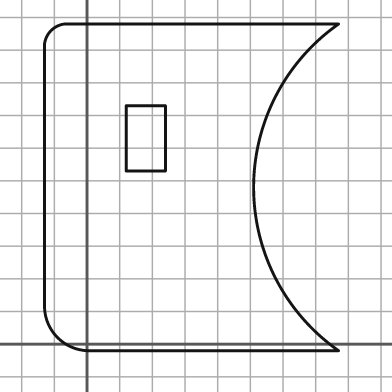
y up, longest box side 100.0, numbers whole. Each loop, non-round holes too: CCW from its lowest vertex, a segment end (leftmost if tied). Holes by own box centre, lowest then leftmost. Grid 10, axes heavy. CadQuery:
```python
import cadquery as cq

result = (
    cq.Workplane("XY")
    .moveTo(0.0, -2.0)
    .lineTo(77.0, -2.0)
    .threePointArc((51.0, 48.0), (77.0, 98.0))
    .lineTo(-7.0, 98.0)
    .threePointArc((-11.0, 96.0), (-13.0, 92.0))
    .lineTo(-13.0, 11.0)
    .threePointArc((-9.0, 2.0), (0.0, -2.0))
    .close()
    .moveTo(12.0, 53.0)
    .lineTo(24.0, 53.0)
    .lineTo(24.0, 73.0)
    .lineTo(12.0, 73.0)
    .close()
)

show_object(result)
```